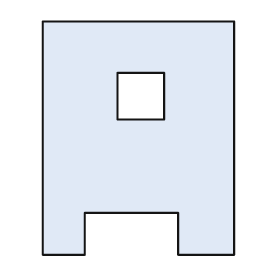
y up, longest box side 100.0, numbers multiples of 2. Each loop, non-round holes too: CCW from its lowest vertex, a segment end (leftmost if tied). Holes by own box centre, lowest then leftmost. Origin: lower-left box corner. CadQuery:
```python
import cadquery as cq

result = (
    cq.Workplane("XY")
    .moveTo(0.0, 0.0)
    .lineTo(18.0, 0.0)
    .lineTo(18.0, 18.0)
    .lineTo(58.0, 18.0)
    .lineTo(58.0, 0.0)
    .lineTo(82.0, 0.0)
    .lineTo(82.0, 100.0)
    .lineTo(0.0, 100.0)
    .close()
    .moveTo(32.0, 58.0)
    .lineTo(52.0, 58.0)
    .lineTo(52.0, 78.0)
    .lineTo(32.0, 78.0)
    .close()
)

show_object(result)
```